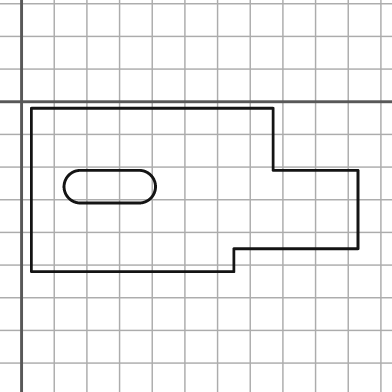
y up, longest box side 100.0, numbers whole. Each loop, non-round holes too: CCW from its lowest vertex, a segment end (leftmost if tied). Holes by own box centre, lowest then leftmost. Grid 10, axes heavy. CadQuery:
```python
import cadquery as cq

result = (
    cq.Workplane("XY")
    .moveTo(3.0, -52.0)
    .lineTo(65.0, -52.0)
    .lineTo(65.0, -45.0)
    .lineTo(103.0, -45.0)
    .lineTo(103.0, -21.0)
    .lineTo(77.0, -21.0)
    .lineTo(77.0, -2.0)
    .lineTo(3.0, -2.0)
    .close()
    .moveTo(18.0, -31.0)
    .lineTo(36.0, -31.0)
    .threePointArc((41.0, -26.0), (36.0, -21.0))
    .lineTo(18.0, -21.0)
    .threePointArc((13.0, -26.0), (18.0, -31.0))
    .close()
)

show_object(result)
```